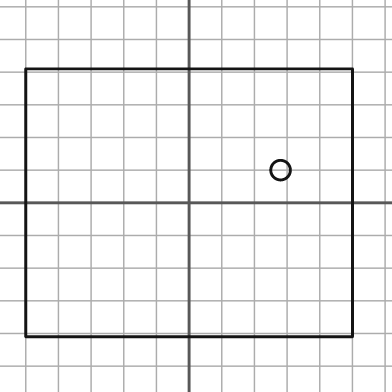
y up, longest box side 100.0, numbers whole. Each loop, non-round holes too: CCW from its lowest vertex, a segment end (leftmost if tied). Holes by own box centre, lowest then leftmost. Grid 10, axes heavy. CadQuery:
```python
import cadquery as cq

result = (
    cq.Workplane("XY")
    .moveTo(-50.0, -41.0)
    .lineTo(50.0, -41.0)
    .lineTo(50.0, 41.0)
    .lineTo(-50.0, 41.0)
    .close()
    .moveTo(28.0, 10.0)
    .circle(3.0)
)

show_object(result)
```